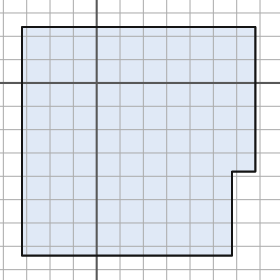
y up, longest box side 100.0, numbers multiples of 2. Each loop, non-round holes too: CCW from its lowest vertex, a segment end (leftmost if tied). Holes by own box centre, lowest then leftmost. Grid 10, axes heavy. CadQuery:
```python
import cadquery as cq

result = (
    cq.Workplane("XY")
    .moveTo(-32.0, -74.0)
    .lineTo(58.0, -74.0)
    .lineTo(58.0, -38.0)
    .lineTo(68.0, -38.0)
    .lineTo(68.0, 24.0)
    .lineTo(-32.0, 24.0)
    .close()
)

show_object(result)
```